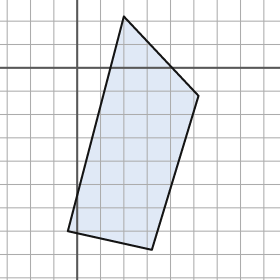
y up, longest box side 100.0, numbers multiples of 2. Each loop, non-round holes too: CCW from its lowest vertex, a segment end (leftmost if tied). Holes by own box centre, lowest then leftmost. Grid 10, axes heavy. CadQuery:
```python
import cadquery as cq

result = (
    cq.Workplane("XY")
    .moveTo(32.0, -78.0)
    .lineTo(52.0, -12.0)
    .lineTo(20.0, 22.0)
    .lineTo(-4.0, -70.0)
    .close()
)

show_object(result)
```